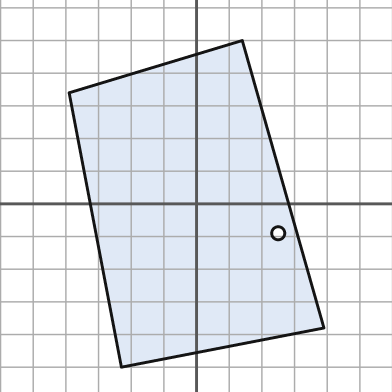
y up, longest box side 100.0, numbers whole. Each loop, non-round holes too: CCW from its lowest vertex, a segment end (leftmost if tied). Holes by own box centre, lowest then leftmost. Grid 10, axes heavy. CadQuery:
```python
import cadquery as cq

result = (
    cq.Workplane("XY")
    .moveTo(-23.0, -50.0)
    .lineTo(39.0, -38.0)
    .lineTo(14.0, 50.0)
    .lineTo(-39.0, 34.0)
    .close()
    .moveTo(25.0, -9.0)
    .circle(2.0)
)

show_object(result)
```